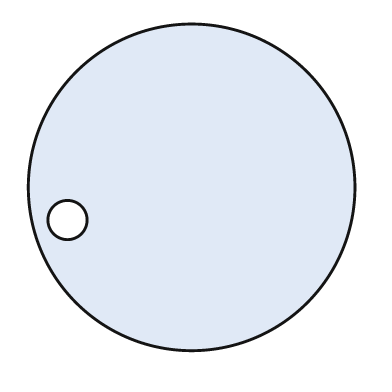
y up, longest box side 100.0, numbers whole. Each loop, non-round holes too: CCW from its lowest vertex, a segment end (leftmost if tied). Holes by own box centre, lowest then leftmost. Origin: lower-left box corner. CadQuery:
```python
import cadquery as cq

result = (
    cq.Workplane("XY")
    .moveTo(50.0, 50.0)
    .circle(50.0)
    .moveTo(12.0, 40.0)
    .circle(6.0)
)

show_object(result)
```